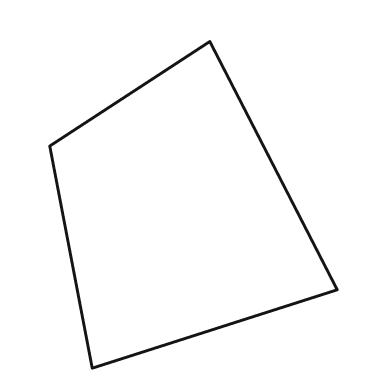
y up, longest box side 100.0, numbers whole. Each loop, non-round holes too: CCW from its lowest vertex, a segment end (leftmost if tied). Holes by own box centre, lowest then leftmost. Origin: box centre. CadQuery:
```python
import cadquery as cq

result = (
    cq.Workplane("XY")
    .moveTo(-31.0, -50.0)
    .lineTo(44.0, -26.0)
    .lineTo(5.0, 50.0)
    .lineTo(-44.0, 18.0)
    .close()
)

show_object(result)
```